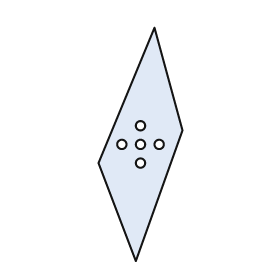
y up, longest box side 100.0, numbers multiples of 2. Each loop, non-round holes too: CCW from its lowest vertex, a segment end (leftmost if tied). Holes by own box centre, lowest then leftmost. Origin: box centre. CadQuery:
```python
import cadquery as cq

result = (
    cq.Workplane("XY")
    .moveTo(-2.0, -50.0)
    .lineTo(18.0, 6.0)
    .lineTo(6.0, 50.0)
    .lineTo(-18.0, -8.0)
    .close()
    .moveTo(0.0, -8.0)
    .circle(2.0)
    .moveTo(-8.0, 0.0)
    .circle(2.0)
    .moveTo(0.0, 0.0)
    .circle(2.0)
    .moveTo(8.0, 0.0)
    .circle(2.0)
    .moveTo(0.0, 8.0)
    .circle(2.0)
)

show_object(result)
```